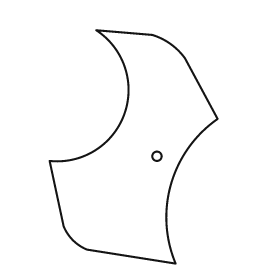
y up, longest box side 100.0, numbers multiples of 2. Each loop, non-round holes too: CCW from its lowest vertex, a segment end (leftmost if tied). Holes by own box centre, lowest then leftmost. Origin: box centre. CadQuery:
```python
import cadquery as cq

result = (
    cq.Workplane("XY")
    .moveTo(18.0, -50.0)
    .threePointArc((16.0, -16.0), (36.0, 12.0))
    .lineTo(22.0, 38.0)
    .threePointArc((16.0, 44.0), (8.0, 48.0))
    .lineTo(-16.0, 50.0)
    .threePointArc((-4.0, 14.0), (-36.0, -6.0))
    .lineTo(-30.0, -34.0)
    .threePointArc((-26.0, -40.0), (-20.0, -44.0))
    .close()
    .moveTo(10.0, -4.0)
    .circle(2.0)
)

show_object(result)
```